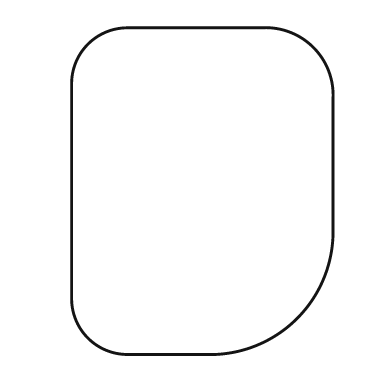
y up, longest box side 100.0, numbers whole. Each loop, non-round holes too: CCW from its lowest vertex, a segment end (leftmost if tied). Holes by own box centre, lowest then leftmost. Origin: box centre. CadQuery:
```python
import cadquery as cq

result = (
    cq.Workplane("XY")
    .moveTo(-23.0, -50.0)
    .lineTo(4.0, -50.0)
    .threePointArc((29.0, -39.0), (40.0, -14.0))
    .lineTo(40.0, 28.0)
    .threePointArc((34.0, 44.0), (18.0, 50.0))
    .lineTo(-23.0, 50.0)
    .threePointArc((-35.0, 45.0), (-40.0, 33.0))
    .lineTo(-40.0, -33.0)
    .threePointArc((-35.0, -45.0), (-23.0, -50.0))
    .close()
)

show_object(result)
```